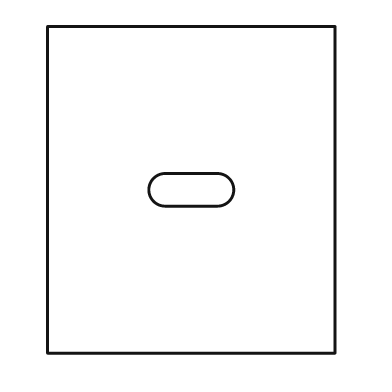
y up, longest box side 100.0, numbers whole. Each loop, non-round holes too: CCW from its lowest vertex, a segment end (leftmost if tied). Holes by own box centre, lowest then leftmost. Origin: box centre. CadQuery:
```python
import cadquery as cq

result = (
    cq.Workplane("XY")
    .moveTo(-44.0, -50.0)
    .lineTo(44.0, -50.0)
    .lineTo(44.0, 50.0)
    .lineTo(-44.0, 50.0)
    .close()
    .moveTo(-8.0, -5.0)
    .lineTo(8.0, -5.0)
    .threePointArc((13.0, 0.0), (8.0, 5.0))
    .lineTo(-8.0, 5.0)
    .threePointArc((-13.0, 0.0), (-8.0, -5.0))
    .close()
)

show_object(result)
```